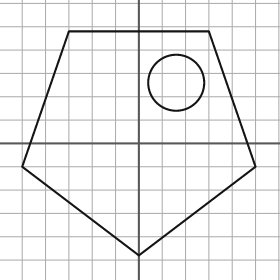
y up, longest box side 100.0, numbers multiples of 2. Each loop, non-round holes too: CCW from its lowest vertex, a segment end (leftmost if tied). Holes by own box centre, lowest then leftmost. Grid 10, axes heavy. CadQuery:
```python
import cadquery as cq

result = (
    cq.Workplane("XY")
    .moveTo(0.0, -48.0)
    .lineTo(50.0, -10.0)
    .lineTo(30.0, 48.0)
    .lineTo(-30.0, 48.0)
    .lineTo(-50.0, -10.0)
    .close()
    .moveTo(16.0, 26.0)
    .circle(12.0)
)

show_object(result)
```